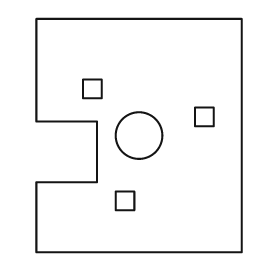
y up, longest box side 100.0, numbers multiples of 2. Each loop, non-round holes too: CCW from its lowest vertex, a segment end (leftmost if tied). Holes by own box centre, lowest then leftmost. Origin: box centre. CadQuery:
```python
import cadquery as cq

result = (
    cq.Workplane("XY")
    .moveTo(-44.0, -50.0)
    .lineTo(44.0, -50.0)
    .lineTo(44.0, 50.0)
    .lineTo(-44.0, 50.0)
    .lineTo(-44.0, 6.0)
    .lineTo(-18.0, 6.0)
    .lineTo(-18.0, -20.0)
    .lineTo(-44.0, -20.0)
    .close()
    .moveTo(-10.0, -32.0)
    .lineTo(-2.0, -32.0)
    .lineTo(-2.0, -24.0)
    .lineTo(-10.0, -24.0)
    .close()
    .moveTo(0.0, 0.0)
    .circle(10.0)
    .moveTo(24.0, 4.0)
    .lineTo(32.0, 4.0)
    .lineTo(32.0, 12.0)
    .lineTo(24.0, 12.0)
    .close()
    .moveTo(-24.0, 16.0)
    .lineTo(-16.0, 16.0)
    .lineTo(-16.0, 24.0)
    .lineTo(-24.0, 24.0)
    .close()
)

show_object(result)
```